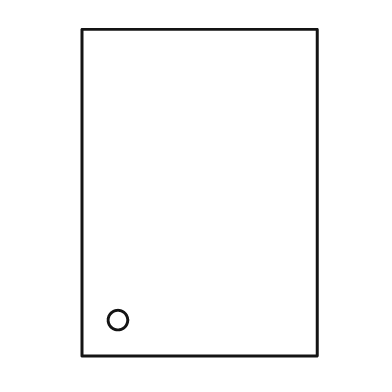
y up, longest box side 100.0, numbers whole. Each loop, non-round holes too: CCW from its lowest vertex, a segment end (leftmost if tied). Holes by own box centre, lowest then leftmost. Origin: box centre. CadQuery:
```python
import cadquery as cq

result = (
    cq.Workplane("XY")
    .moveTo(-36.0, -50.0)
    .lineTo(36.0, -50.0)
    .lineTo(36.0, 50.0)
    .lineTo(-36.0, 50.0)
    .close()
    .moveTo(-25.0, -39.0)
    .circle(3.0)
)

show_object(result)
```